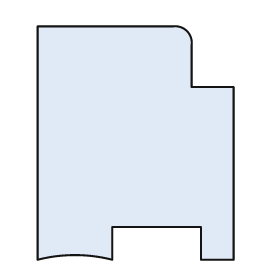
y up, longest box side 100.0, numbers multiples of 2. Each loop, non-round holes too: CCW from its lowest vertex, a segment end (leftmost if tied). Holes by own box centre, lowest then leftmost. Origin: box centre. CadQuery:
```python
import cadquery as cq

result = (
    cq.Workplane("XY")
    .moveTo(-42.0, -50.0)
    .threePointArc((-26.0, -48.0), (-10.0, -50.0))
    .lineTo(-10.0, -36.0)
    .lineTo(28.0, -36.0)
    .lineTo(28.0, -50.0)
    .lineTo(42.0, -50.0)
    .lineTo(42.0, 24.0)
    .lineTo(24.0, 24.0)
    .lineTo(24.0, 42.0)
    .threePointArc((22.0, 48.0), (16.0, 50.0))
    .lineTo(-42.0, 50.0)
    .close()
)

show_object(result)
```